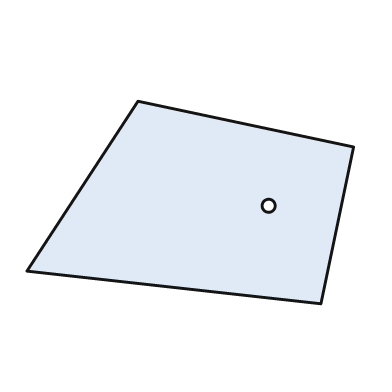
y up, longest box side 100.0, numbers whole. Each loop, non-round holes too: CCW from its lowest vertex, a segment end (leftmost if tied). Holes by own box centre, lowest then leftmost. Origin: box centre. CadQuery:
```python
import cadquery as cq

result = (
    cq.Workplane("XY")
    .moveTo(40.0, -31.0)
    .lineTo(50.0, 17.0)
    .lineTo(-16.0, 31.0)
    .lineTo(-50.0, -21.0)
    .close()
    .moveTo(24.0, -1.0)
    .circle(2.0)
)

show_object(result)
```